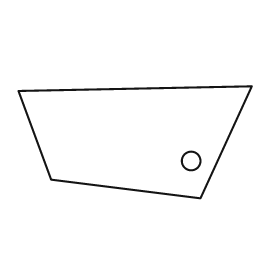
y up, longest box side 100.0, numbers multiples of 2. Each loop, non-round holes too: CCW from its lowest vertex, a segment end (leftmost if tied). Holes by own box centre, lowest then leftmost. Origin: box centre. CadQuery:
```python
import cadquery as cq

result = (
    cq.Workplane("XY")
    .moveTo(28.0, -24.0)
    .lineTo(50.0, 24.0)
    .lineTo(-50.0, 22.0)
    .lineTo(-36.0, -16.0)
    .close()
    .moveTo(24.0, -8.0)
    .circle(4.0)
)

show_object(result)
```